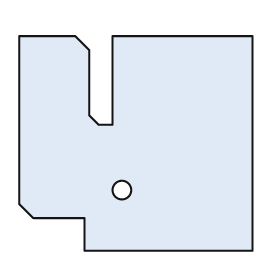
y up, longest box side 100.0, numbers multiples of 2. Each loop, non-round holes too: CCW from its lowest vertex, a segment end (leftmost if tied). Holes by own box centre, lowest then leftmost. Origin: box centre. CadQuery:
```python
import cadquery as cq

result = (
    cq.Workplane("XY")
    .moveTo(-22.0, -46.0)
    .lineTo(50.0, -46.0)
    .lineTo(50.0, 46.0)
    .lineTo(-10.0, 46.0)
    .lineTo(-10.0, 8.0)
    .lineTo(-16.0, 8.0)
    .lineTo(-20.0, 12.0)
    .lineTo(-20.0, 40.0)
    .lineTo(-26.0, 46.0)
    .lineTo(-50.0, 46.0)
    .lineTo(-50.0, -26.0)
    .lineTo(-44.0, -32.0)
    .lineTo(-22.0, -32.0)
    .close()
    .moveTo(-6.0, -20.0)
    .circle(4.0)
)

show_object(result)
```